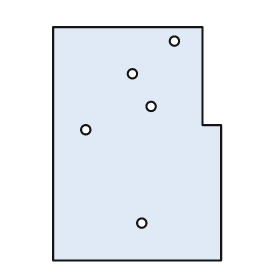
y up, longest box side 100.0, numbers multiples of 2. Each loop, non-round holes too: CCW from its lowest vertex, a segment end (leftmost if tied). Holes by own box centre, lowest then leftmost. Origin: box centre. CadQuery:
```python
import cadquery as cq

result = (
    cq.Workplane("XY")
    .moveTo(-36.0, -50.0)
    .lineTo(36.0, -50.0)
    .lineTo(36.0, 8.0)
    .lineTo(28.0, 8.0)
    .lineTo(28.0, 50.0)
    .lineTo(-36.0, 50.0)
    .close()
    .moveTo(2.0, -34.0)
    .circle(2.0)
    .moveTo(-22.0, 6.0)
    .circle(2.0)
    .moveTo(6.0, 16.0)
    .circle(2.0)
    .moveTo(-2.0, 30.0)
    .circle(2.0)
    .moveTo(16.0, 44.0)
    .circle(2.0)
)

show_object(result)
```